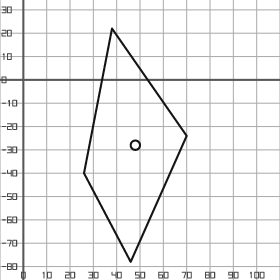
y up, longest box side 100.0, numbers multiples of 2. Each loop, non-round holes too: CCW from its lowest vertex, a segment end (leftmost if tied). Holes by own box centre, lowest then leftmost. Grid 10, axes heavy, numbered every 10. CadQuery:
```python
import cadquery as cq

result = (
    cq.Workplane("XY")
    .moveTo(46.0, -78.0)
    .lineTo(70.0, -24.0)
    .lineTo(38.0, 22.0)
    .lineTo(26.0, -40.0)
    .close()
    .moveTo(48.0, -28.0)
    .circle(2.0)
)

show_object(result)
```